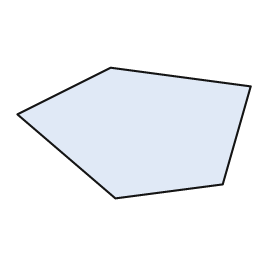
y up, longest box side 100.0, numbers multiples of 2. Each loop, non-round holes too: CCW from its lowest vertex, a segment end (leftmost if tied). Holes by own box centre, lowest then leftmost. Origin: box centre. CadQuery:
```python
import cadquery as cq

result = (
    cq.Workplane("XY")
    .moveTo(-8.0, -28.0)
    .lineTo(38.0, -22.0)
    .lineTo(50.0, 20.0)
    .lineTo(-10.0, 28.0)
    .lineTo(-50.0, 8.0)
    .close()
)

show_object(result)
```